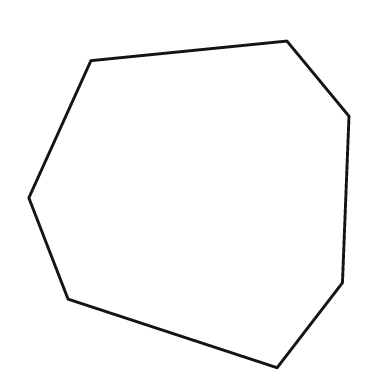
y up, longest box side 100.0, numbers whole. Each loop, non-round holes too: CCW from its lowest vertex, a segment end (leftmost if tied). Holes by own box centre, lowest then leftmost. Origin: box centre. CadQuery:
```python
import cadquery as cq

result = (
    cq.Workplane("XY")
    .moveTo(27.0, -50.0)
    .lineTo(47.0, -24.0)
    .lineTo(49.0, 27.0)
    .lineTo(30.0, 50.0)
    .lineTo(-30.0, 44.0)
    .lineTo(-49.0, 2.0)
    .lineTo(-37.0, -29.0)
    .close()
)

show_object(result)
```